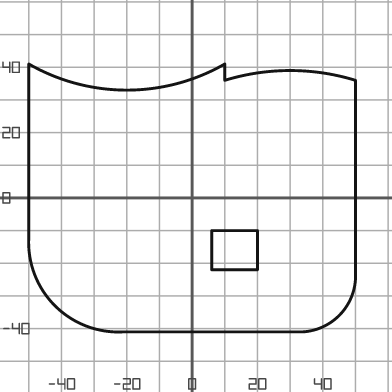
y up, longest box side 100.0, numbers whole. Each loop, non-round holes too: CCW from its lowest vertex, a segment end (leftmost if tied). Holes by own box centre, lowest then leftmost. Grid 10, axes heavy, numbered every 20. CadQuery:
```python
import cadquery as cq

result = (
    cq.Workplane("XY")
    .moveTo(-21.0, -41.0)
    .lineTo(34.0, -41.0)
    .threePointArc((45.0, -36.0), (50.0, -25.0))
    .lineTo(50.0, 36.0)
    .threePointArc((30.0, 39.0), (10.0, 36.0))
    .lineTo(10.0, 41.0)
    .threePointArc((-20.0, 33.0), (-50.0, 41.0))
    .lineTo(-50.0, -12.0)
    .threePointArc((-42.0, -33.0), (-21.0, -41.0))
    .close()
    .moveTo(6.0, -22.0)
    .lineTo(20.0, -22.0)
    .lineTo(20.0, -10.0)
    .lineTo(6.0, -10.0)
    .close()
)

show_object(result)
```